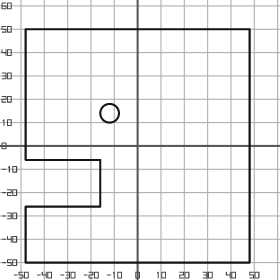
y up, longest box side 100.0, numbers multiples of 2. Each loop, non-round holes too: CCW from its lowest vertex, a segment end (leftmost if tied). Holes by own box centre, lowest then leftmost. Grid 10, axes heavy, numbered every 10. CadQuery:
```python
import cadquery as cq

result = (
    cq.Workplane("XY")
    .moveTo(-48.0, -50.0)
    .lineTo(48.0, -50.0)
    .lineTo(48.0, 50.0)
    .lineTo(-48.0, 50.0)
    .lineTo(-48.0, -6.0)
    .lineTo(-16.0, -6.0)
    .lineTo(-16.0, -26.0)
    .lineTo(-48.0, -26.0)
    .close()
    .moveTo(-12.0, 14.0)
    .circle(4.0)
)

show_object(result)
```